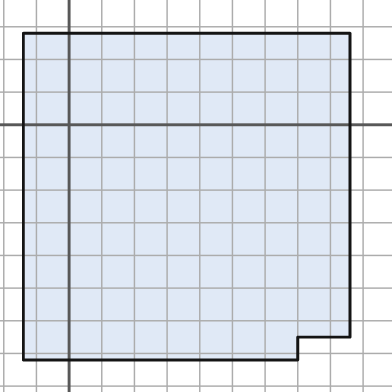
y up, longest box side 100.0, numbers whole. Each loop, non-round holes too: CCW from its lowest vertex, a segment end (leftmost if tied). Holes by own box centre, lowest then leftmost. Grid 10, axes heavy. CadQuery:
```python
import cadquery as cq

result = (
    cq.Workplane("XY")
    .moveTo(-14.0, -72.0)
    .lineTo(70.0, -72.0)
    .lineTo(70.0, -65.0)
    .lineTo(86.0, -65.0)
    .lineTo(86.0, 28.0)
    .lineTo(-14.0, 28.0)
    .close()
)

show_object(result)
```